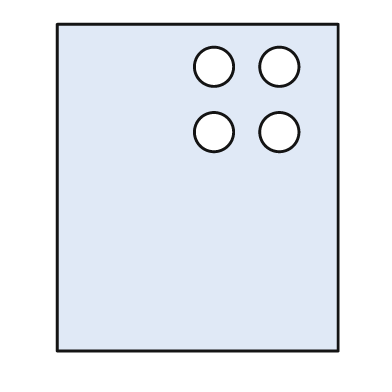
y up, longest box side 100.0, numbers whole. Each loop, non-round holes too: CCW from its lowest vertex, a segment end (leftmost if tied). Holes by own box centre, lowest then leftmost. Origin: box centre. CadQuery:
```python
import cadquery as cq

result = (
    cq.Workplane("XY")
    .moveTo(-43.0, -50.0)
    .lineTo(43.0, -50.0)
    .lineTo(43.0, 50.0)
    .lineTo(-43.0, 50.0)
    .close()
    .moveTo(5.0, 17.0)
    .circle(6.0)
    .moveTo(25.0, 17.0)
    .circle(6.0)
    .moveTo(5.0, 37.0)
    .circle(6.0)
    .moveTo(25.0, 37.0)
    .circle(6.0)
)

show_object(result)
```